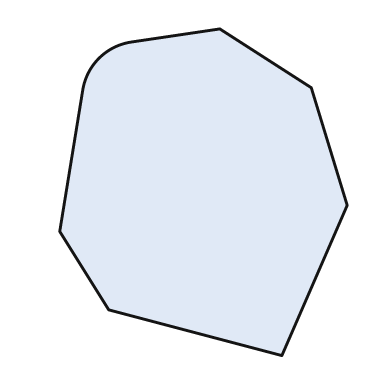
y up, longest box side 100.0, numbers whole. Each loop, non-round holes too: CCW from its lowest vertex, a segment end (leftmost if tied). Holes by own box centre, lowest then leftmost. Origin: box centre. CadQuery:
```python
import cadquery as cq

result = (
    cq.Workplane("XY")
    .moveTo(24.0, -50.0)
    .lineTo(44.0, -4.0)
    .lineTo(33.0, 32.0)
    .lineTo(5.0, 50.0)
    .lineTo(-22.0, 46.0)
    .threePointArc((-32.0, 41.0), (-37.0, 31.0))
    .lineTo(-44.0, -12.0)
    .lineTo(-29.0, -36.0)
    .close()
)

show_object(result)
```